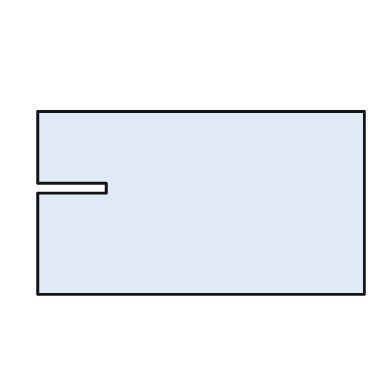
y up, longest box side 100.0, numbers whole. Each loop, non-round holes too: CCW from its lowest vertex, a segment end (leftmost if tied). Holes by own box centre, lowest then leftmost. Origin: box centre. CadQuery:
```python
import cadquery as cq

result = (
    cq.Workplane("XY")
    .moveTo(-50.0, -28.0)
    .lineTo(50.0, -28.0)
    .lineTo(50.0, 28.0)
    .lineTo(-50.0, 28.0)
    .lineTo(-50.0, 6.0)
    .lineTo(-29.0, 6.0)
    .lineTo(-29.0, 3.0)
    .lineTo(-50.0, 3.0)
    .close()
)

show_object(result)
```